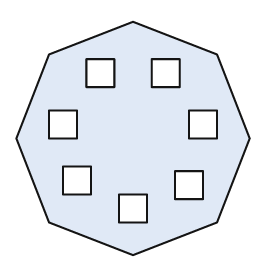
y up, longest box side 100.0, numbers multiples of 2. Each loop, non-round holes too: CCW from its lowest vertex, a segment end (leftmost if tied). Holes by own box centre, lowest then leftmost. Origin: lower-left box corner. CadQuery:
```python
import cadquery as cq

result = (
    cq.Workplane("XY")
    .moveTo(50.0, 0.0)
    .lineTo(86.0, 14.0)
    .lineTo(100.0, 50.0)
    .lineTo(86.0, 86.0)
    .lineTo(50.0, 100.0)
    .lineTo(14.0, 86.0)
    .lineTo(0.0, 50.0)
    .lineTo(14.0, 14.0)
    .close()
    .moveTo(44.0, 14.0)
    .lineTo(56.0, 14.0)
    .lineTo(56.0, 26.0)
    .lineTo(44.0, 26.0)
    .close()
    .moveTo(68.0, 24.0)
    .lineTo(80.0, 24.0)
    .lineTo(80.0, 36.0)
    .lineTo(68.0, 36.0)
    .close()
    .moveTo(20.0, 26.0)
    .lineTo(32.0, 26.0)
    .lineTo(32.0, 38.0)
    .lineTo(20.0, 38.0)
    .close()
    .moveTo(14.0, 50.0)
    .lineTo(26.0, 50.0)
    .lineTo(26.0, 62.0)
    .lineTo(14.0, 62.0)
    .close()
    .moveTo(74.0, 50.0)
    .lineTo(86.0, 50.0)
    .lineTo(86.0, 62.0)
    .lineTo(74.0, 62.0)
    .close()
    .moveTo(30.0, 72.0)
    .lineTo(42.0, 72.0)
    .lineTo(42.0, 84.0)
    .lineTo(30.0, 84.0)
    .close()
    .moveTo(58.0, 72.0)
    .lineTo(70.0, 72.0)
    .lineTo(70.0, 84.0)
    .lineTo(58.0, 84.0)
    .close()
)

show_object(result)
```